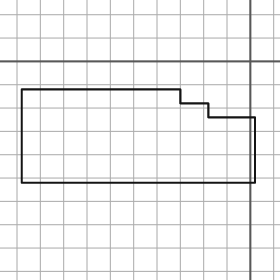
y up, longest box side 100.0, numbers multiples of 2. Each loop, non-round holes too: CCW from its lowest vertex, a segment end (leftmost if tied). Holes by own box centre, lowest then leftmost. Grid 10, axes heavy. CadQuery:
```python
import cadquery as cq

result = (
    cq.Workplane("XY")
    .moveTo(-98.0, -52.0)
    .lineTo(2.0, -52.0)
    .lineTo(2.0, -24.0)
    .lineTo(-18.0, -24.0)
    .lineTo(-18.0, -18.0)
    .lineTo(-30.0, -18.0)
    .lineTo(-30.0, -12.0)
    .lineTo(-98.0, -12.0)
    .close()
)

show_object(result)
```